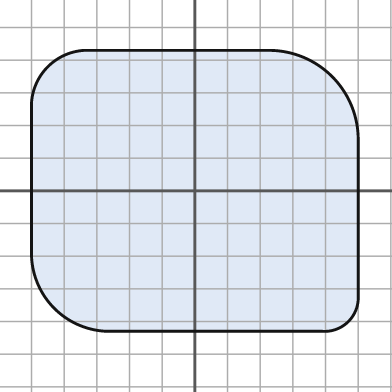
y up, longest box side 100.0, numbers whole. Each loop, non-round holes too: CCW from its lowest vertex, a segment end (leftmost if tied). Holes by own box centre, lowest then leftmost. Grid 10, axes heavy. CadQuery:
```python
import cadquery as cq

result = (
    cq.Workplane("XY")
    .moveTo(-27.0, -43.0)
    .lineTo(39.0, -43.0)
    .threePointArc((47.0, -40.0), (50.0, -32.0))
    .lineTo(50.0, 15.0)
    .threePointArc((42.0, 35.0), (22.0, 43.0))
    .lineTo(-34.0, 43.0)
    .threePointArc((-45.0, 38.0), (-50.0, 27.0))
    .lineTo(-50.0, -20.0)
    .threePointArc((-43.0, -36.0), (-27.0, -43.0))
    .close()
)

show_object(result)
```